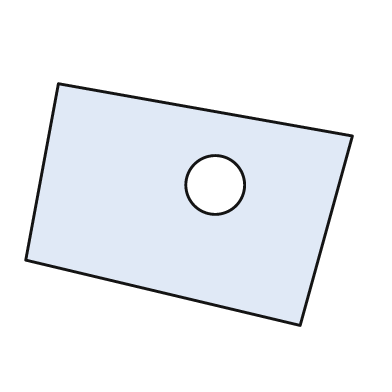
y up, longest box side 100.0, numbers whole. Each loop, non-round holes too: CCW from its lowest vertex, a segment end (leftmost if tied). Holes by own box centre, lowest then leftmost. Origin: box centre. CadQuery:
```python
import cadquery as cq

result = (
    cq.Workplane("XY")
    .moveTo(34.0, -37.0)
    .lineTo(50.0, 21.0)
    .lineTo(-40.0, 37.0)
    .lineTo(-50.0, -17.0)
    .close()
    .moveTo(8.0, 6.0)
    .circle(9.0)
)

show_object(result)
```